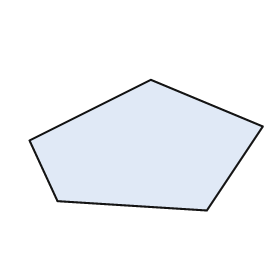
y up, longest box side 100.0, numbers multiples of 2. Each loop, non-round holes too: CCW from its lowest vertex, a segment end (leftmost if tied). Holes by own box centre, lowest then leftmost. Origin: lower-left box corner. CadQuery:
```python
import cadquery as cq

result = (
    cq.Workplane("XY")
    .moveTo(76.0, 0.0)
    .lineTo(100.0, 36.0)
    .lineTo(52.0, 56.0)
    .lineTo(0.0, 30.0)
    .lineTo(12.0, 4.0)
    .close()
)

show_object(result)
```